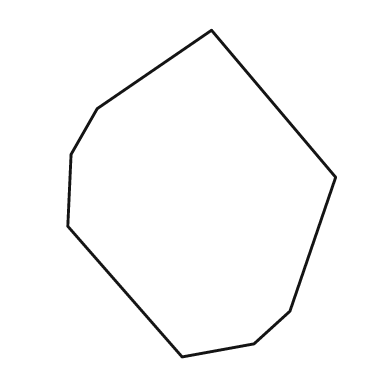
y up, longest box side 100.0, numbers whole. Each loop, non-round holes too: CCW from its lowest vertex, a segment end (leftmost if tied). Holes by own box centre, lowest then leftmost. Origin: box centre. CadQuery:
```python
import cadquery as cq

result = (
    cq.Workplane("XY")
    .moveTo(-6.0, -50.0)
    .lineTo(16.0, -46.0)
    .lineTo(27.0, -36.0)
    .lineTo(41.0, 5.0)
    .lineTo(3.0, 50.0)
    .lineTo(-32.0, 26.0)
    .lineTo(-40.0, 12.0)
    .lineTo(-41.0, -10.0)
    .close()
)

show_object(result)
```